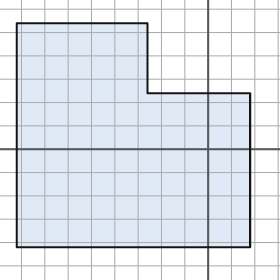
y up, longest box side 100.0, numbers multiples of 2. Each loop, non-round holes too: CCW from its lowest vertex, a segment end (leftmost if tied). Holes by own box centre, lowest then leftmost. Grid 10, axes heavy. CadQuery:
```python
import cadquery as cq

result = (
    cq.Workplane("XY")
    .moveTo(-82.0, -42.0)
    .lineTo(18.0, -42.0)
    .lineTo(18.0, 24.0)
    .lineTo(-26.0, 24.0)
    .lineTo(-26.0, 54.0)
    .lineTo(-82.0, 54.0)
    .close()
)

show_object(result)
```